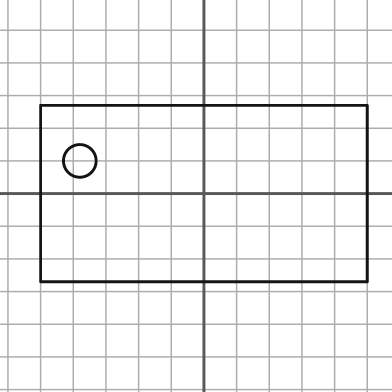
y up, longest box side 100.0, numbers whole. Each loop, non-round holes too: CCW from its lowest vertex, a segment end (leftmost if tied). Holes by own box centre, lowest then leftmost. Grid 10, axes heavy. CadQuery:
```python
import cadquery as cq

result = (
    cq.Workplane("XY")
    .moveTo(-50.0, -27.0)
    .lineTo(50.0, -27.0)
    .lineTo(50.0, 27.0)
    .lineTo(-50.0, 27.0)
    .close()
    .moveTo(-38.0, 10.0)
    .circle(5.0)
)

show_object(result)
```